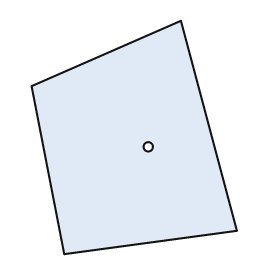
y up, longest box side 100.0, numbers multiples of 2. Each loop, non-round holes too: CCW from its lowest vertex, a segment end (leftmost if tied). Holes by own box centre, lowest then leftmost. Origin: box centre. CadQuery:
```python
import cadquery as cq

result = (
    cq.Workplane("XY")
    .moveTo(-30.0, -50.0)
    .lineTo(44.0, -40.0)
    .lineTo(20.0, 50.0)
    .lineTo(-44.0, 22.0)
    .close()
    .moveTo(6.0, -4.0)
    .circle(2.0)
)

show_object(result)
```